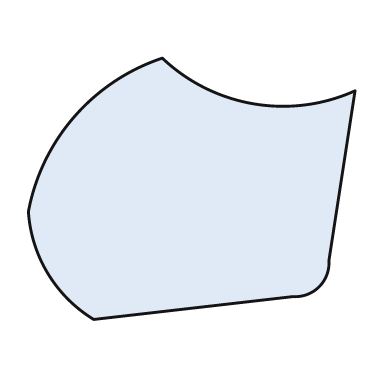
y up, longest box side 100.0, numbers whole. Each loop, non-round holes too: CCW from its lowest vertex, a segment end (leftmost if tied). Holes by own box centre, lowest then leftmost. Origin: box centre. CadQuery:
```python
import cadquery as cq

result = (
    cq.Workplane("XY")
    .moveTo(-30.0, -40.0)
    .lineTo(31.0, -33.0)
    .threePointArc((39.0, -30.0), (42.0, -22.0))
    .lineTo(50.0, 30.0)
    .threePointArc((19.0, 26.0), (-9.0, 40.0))
    .threePointArc((-36.0, 22.0), (-50.0, -7.0))
    .threePointArc((-44.0, -26.0), (-30.0, -40.0))
    .close()
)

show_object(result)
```